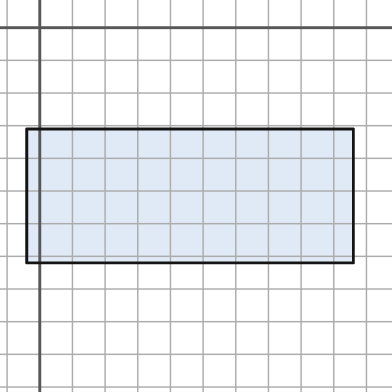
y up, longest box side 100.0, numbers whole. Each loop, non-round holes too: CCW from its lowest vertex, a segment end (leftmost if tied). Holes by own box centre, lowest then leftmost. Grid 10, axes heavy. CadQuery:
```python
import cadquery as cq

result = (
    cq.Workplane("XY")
    .moveTo(-4.0, -72.0)
    .lineTo(96.0, -72.0)
    .lineTo(96.0, -31.0)
    .lineTo(-4.0, -31.0)
    .close()
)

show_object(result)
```